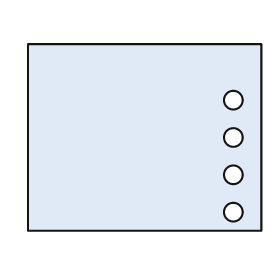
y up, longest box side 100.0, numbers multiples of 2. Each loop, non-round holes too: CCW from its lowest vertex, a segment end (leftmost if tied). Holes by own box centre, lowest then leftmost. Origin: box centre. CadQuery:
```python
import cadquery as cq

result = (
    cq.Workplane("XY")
    .moveTo(-50.0, -40.0)
    .lineTo(50.0, -40.0)
    .lineTo(50.0, 40.0)
    .lineTo(-50.0, 40.0)
    .close()
    .moveTo(38.0, -32.0)
    .circle(4.0)
    .moveTo(38.0, -16.0)
    .circle(4.0)
    .moveTo(38.0, 0.0)
    .circle(4.0)
    .moveTo(38.0, 16.0)
    .circle(4.0)
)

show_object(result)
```